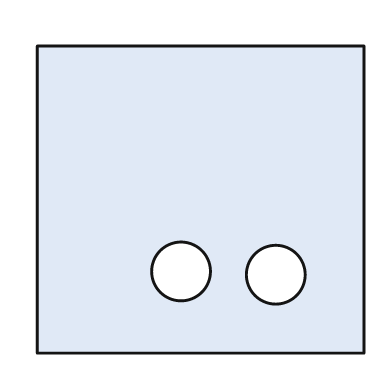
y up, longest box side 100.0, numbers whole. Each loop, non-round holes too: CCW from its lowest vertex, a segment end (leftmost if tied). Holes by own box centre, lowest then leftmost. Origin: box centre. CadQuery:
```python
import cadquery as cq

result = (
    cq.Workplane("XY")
    .moveTo(-50.0, -47.0)
    .lineTo(50.0, -47.0)
    .lineTo(50.0, 47.0)
    .lineTo(-50.0, 47.0)
    .close()
    .moveTo(23.0, -23.0)
    .circle(9.0)
    .moveTo(-6.0, -22.0)
    .circle(9.0)
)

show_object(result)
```